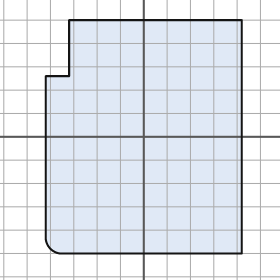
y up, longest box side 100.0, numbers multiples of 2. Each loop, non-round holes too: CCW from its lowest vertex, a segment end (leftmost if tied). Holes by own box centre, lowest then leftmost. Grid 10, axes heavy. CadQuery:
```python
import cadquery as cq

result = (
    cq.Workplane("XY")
    .moveTo(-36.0, -50.0)
    .lineTo(42.0, -50.0)
    .lineTo(42.0, 50.0)
    .lineTo(-32.0, 50.0)
    .lineTo(-32.0, 26.0)
    .lineTo(-42.0, 26.0)
    .lineTo(-42.0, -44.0)
    .threePointArc((-40.0, -48.0), (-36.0, -50.0))
    .close()
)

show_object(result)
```